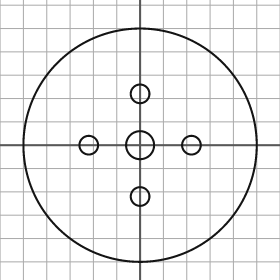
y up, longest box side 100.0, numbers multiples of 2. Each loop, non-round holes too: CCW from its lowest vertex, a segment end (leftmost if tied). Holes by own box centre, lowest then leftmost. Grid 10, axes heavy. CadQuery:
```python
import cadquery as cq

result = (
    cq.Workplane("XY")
    .moveTo(0.0, 0.0)
    .circle(50.0)
    .moveTo(0.0, -22.0)
    .circle(4.0)
    .moveTo(-22.0, 0.0)
    .circle(4.0)
    .moveTo(0.0, 0.0)
    .circle(6.0)
    .moveTo(22.0, 0.0)
    .circle(4.0)
    .moveTo(0.0, 22.0)
    .circle(4.0)
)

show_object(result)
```